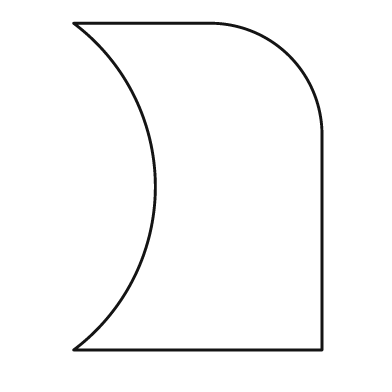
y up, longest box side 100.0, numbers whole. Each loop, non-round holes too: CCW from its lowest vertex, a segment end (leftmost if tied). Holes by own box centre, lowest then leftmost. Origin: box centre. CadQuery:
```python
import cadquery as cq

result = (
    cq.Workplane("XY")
    .moveTo(-38.0, -50.0)
    .lineTo(38.0, -50.0)
    .lineTo(38.0, 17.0)
    .threePointArc((28.0, 40.0), (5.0, 50.0))
    .lineTo(-38.0, 50.0)
    .threePointArc((-13.0, 0.0), (-38.0, -50.0))
    .close()
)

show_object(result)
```